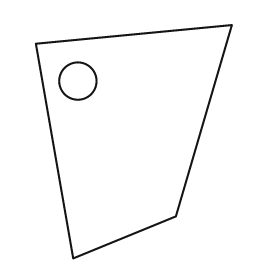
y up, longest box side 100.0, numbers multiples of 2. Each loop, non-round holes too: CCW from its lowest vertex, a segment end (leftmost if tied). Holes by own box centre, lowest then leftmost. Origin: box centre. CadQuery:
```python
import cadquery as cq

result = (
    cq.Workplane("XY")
    .moveTo(-26.0, -50.0)
    .lineTo(18.0, -32.0)
    .lineTo(42.0, 50.0)
    .lineTo(-42.0, 42.0)
    .close()
    .moveTo(-24.0, 26.0)
    .circle(8.0)
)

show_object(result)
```